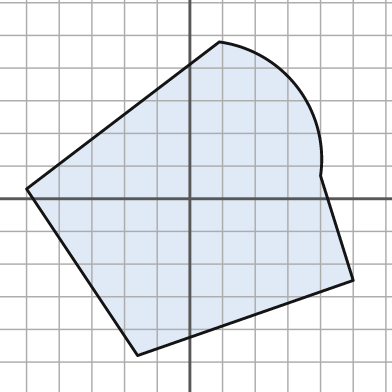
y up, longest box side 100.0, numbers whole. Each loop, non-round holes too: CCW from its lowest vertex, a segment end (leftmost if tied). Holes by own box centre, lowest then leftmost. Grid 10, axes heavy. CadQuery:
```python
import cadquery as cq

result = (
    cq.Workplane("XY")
    .moveTo(-16.0, -48.0)
    .lineTo(50.0, -25.0)
    .lineTo(40.0, 7.0)
    .threePointArc((33.0, 34.0), (9.0, 48.0))
    .lineTo(-50.0, 3.0)
    .close()
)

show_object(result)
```